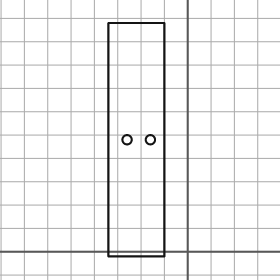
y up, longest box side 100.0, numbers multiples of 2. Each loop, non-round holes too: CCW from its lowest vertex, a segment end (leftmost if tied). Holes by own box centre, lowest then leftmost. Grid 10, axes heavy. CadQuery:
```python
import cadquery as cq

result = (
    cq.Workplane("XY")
    .moveTo(-34.0, -2.0)
    .lineTo(-10.0, -2.0)
    .lineTo(-10.0, 98.0)
    .lineTo(-34.0, 98.0)
    .close()
    .moveTo(-26.0, 48.0)
    .circle(2.0)
    .moveTo(-16.0, 48.0)
    .circle(2.0)
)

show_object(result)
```